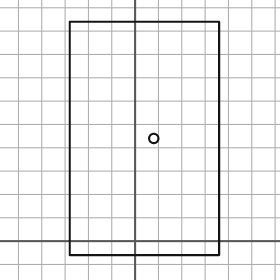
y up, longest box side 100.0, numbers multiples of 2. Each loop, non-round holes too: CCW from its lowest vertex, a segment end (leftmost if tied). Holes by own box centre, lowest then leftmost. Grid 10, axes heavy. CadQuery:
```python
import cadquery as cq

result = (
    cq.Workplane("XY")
    .moveTo(-28.0, -6.0)
    .lineTo(36.0, -6.0)
    .lineTo(36.0, 94.0)
    .lineTo(-28.0, 94.0)
    .close()
    .moveTo(8.0, 44.0)
    .circle(2.0)
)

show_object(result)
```